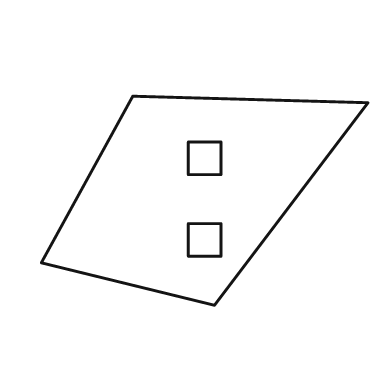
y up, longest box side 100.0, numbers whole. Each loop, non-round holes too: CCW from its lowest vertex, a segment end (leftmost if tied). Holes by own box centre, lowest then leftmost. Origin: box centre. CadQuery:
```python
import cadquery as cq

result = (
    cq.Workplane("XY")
    .moveTo(3.0, -32.0)
    .lineTo(50.0, 30.0)
    .lineTo(-22.0, 32.0)
    .lineTo(-50.0, -19.0)
    .close()
    .moveTo(-5.0, -17.0)
    .lineTo(5.0, -17.0)
    .lineTo(5.0, -7.0)
    .lineTo(-5.0, -7.0)
    .close()
    .moveTo(-5.0, 8.0)
    .lineTo(5.0, 8.0)
    .lineTo(5.0, 18.0)
    .lineTo(-5.0, 18.0)
    .close()
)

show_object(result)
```